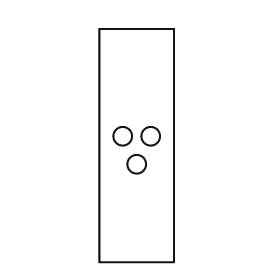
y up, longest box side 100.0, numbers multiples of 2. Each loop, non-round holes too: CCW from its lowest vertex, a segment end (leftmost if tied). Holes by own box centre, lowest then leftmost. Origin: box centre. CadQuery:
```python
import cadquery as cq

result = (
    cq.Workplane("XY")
    .moveTo(-16.0, -50.0)
    .lineTo(16.0, -50.0)
    .lineTo(16.0, 50.0)
    .lineTo(-16.0, 50.0)
    .close()
    .moveTo(0.0, -8.0)
    .circle(4.0)
    .moveTo(-6.0, 4.0)
    .circle(4.0)
    .moveTo(6.0, 4.0)
    .circle(4.0)
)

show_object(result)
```